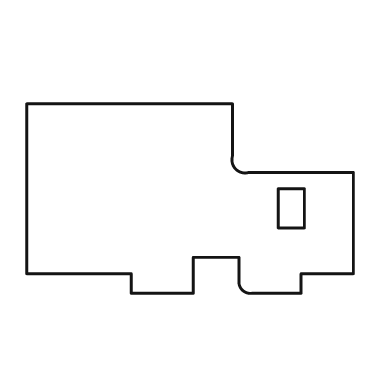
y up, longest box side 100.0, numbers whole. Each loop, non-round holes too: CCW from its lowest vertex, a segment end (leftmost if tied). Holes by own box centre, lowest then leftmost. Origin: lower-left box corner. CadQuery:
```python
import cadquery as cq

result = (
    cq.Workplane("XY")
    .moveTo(32.0, 0.0)
    .lineTo(51.0, 0.0)
    .lineTo(51.0, 11.0)
    .lineTo(65.0, 11.0)
    .lineTo(65.0, 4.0)
    .threePointArc((66.0, 1.0), (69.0, 0.0))
    .lineTo(84.0, 0.0)
    .lineTo(84.0, 6.0)
    .lineTo(100.0, 6.0)
    .lineTo(100.0, 37.0)
    .lineTo(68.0, 37.0)
    .threePointArc((64.0, 38.0), (63.0, 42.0))
    .lineTo(63.0, 58.0)
    .lineTo(0.0, 58.0)
    .lineTo(0.0, 6.0)
    .lineTo(32.0, 6.0)
    .close()
    .moveTo(77.0, 20.0)
    .lineTo(85.0, 20.0)
    .lineTo(85.0, 32.0)
    .lineTo(77.0, 32.0)
    .close()
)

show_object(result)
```